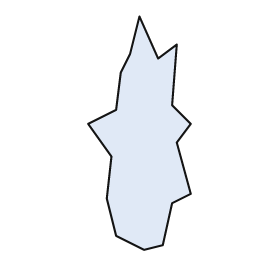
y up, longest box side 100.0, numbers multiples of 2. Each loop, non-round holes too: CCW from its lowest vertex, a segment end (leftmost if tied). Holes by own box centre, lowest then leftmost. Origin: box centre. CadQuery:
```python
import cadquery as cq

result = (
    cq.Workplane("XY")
    .moveTo(2.0, -50.0)
    .lineTo(10.0, -48.0)
    .lineTo(14.0, -30.0)
    .lineTo(22.0, -26.0)
    .lineTo(16.0, -4.0)
    .lineTo(22.0, 4.0)
    .lineTo(14.0, 12.0)
    .lineTo(16.0, 38.0)
    .lineTo(8.0, 32.0)
    .lineTo(0.0, 50.0)
    .lineTo(-4.0, 34.0)
    .lineTo(-8.0, 26.0)
    .lineTo(-10.0, 10.0)
    .lineTo(-22.0, 4.0)
    .lineTo(-12.0, -10.0)
    .lineTo(-14.0, -28.0)
    .lineTo(-10.0, -44.0)
    .close()
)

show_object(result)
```